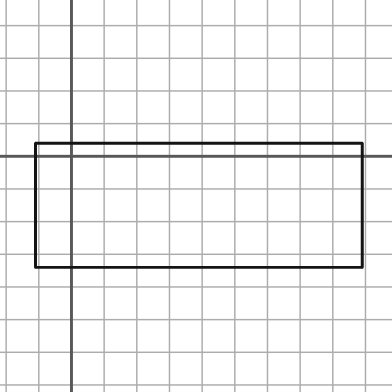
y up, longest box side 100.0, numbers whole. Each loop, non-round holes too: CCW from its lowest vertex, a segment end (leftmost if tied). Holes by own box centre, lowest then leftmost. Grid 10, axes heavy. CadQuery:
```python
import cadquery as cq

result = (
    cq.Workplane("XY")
    .moveTo(-11.0, -34.0)
    .lineTo(89.0, -34.0)
    .lineTo(89.0, 4.0)
    .lineTo(-11.0, 4.0)
    .close()
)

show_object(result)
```